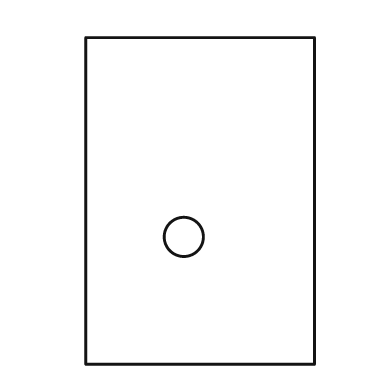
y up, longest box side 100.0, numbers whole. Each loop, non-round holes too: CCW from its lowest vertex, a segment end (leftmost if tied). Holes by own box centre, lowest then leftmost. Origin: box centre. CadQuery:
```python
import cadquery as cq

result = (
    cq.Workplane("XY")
    .moveTo(-35.0, -50.0)
    .lineTo(35.0, -50.0)
    .lineTo(35.0, 50.0)
    .lineTo(-35.0, 50.0)
    .close()
    .moveTo(-5.0, -11.0)
    .circle(6.0)
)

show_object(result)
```